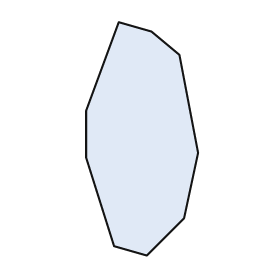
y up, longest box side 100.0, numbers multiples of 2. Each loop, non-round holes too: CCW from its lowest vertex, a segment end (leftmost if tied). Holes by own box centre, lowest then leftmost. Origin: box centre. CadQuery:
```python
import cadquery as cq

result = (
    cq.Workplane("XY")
    .moveTo(2.0, -50.0)
    .lineTo(18.0, -34.0)
    .lineTo(24.0, -6.0)
    .lineTo(16.0, 36.0)
    .lineTo(4.0, 46.0)
    .lineTo(-10.0, 50.0)
    .lineTo(-24.0, 12.0)
    .lineTo(-24.0, -8.0)
    .lineTo(-12.0, -46.0)
    .close()
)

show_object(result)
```